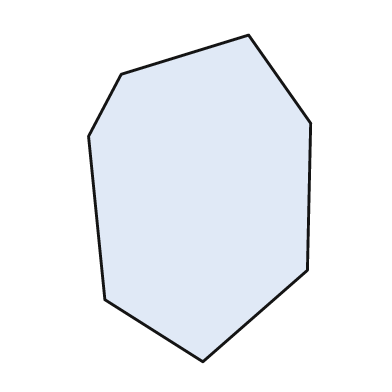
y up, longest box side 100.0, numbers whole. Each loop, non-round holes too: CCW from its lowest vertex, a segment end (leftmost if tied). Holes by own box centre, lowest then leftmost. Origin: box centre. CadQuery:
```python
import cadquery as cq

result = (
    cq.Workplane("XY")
    .moveTo(1.0, -50.0)
    .lineTo(33.0, -22.0)
    .lineTo(34.0, 23.0)
    .lineTo(15.0, 50.0)
    .lineTo(-24.0, 38.0)
    .lineTo(-34.0, 19.0)
    .lineTo(-29.0, -31.0)
    .close()
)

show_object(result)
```